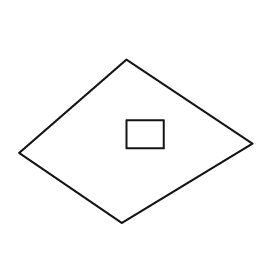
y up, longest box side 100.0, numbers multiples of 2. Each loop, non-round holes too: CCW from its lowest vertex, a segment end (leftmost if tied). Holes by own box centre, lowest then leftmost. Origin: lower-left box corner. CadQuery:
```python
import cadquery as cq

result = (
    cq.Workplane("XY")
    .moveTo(44.0, 0.0)
    .lineTo(100.0, 34.0)
    .lineTo(46.0, 70.0)
    .lineTo(0.0, 30.0)
    .close()
    .moveTo(46.0, 32.0)
    .lineTo(62.0, 32.0)
    .lineTo(62.0, 44.0)
    .lineTo(46.0, 44.0)
    .close()
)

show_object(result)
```